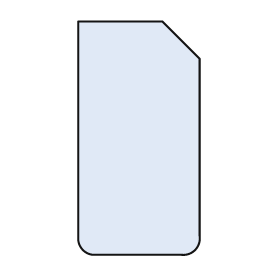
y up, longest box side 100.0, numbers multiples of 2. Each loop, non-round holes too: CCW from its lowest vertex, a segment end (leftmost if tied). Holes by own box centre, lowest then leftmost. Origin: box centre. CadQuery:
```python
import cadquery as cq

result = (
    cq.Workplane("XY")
    .moveTo(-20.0, -50.0)
    .lineTo(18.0, -50.0)
    .threePointArc((24.0, -48.0), (26.0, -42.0))
    .lineTo(26.0, 34.0)
    .lineTo(10.0, 50.0)
    .lineTo(-26.0, 50.0)
    .lineTo(-26.0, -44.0)
    .threePointArc((-24.0, -48.0), (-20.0, -50.0))
    .close()
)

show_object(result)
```